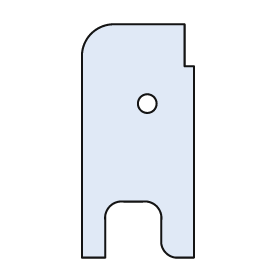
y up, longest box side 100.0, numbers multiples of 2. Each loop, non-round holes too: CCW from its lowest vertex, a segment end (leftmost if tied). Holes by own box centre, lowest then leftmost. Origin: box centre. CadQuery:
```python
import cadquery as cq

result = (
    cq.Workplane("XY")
    .moveTo(-24.0, -50.0)
    .lineTo(-14.0, -50.0)
    .lineTo(-14.0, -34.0)
    .threePointArc((-12.0, -28.0), (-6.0, -26.0))
    .lineTo(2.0, -26.0)
    .threePointArc((8.0, -28.0), (10.0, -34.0))
    .lineTo(10.0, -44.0)
    .threePointArc((12.0, -48.0), (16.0, -50.0))
    .lineTo(24.0, -50.0)
    .lineTo(24.0, 32.0)
    .lineTo(20.0, 32.0)
    .lineTo(20.0, 50.0)
    .lineTo(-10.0, 50.0)
    .threePointArc((-20.0, 46.0), (-24.0, 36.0))
    .close()
    .moveTo(4.0, 16.0)
    .circle(4.0)
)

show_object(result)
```